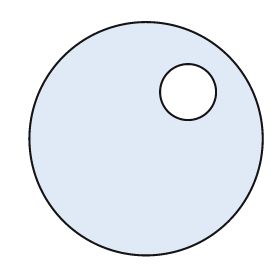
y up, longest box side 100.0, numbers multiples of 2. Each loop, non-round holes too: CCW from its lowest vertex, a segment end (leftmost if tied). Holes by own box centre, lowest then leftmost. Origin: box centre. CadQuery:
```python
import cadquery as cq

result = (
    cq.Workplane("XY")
    .moveTo(0.0, 0.0)
    .circle(50.0)
    .moveTo(18.0, 20.0)
    .circle(12.0)
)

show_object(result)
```